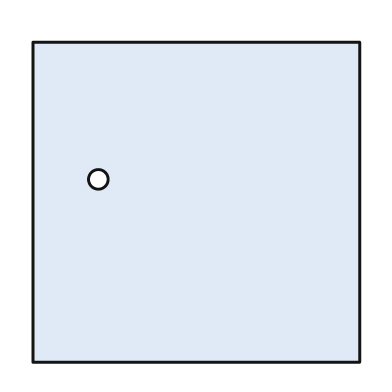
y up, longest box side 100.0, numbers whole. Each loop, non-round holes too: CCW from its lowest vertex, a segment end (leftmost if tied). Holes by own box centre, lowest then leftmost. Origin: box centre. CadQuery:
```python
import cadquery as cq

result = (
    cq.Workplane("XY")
    .moveTo(-50.0, -49.0)
    .lineTo(50.0, -49.0)
    .lineTo(50.0, 49.0)
    .lineTo(-50.0, 49.0)
    .close()
    .moveTo(-30.0, 7.0)
    .circle(3.0)
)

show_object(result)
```